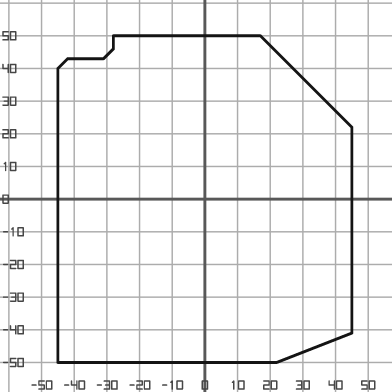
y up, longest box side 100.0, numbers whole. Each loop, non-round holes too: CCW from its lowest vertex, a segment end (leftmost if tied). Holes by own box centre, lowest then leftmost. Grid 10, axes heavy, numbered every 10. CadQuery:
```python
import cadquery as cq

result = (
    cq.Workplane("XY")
    .moveTo(-45.0, -50.0)
    .lineTo(22.0, -50.0)
    .lineTo(45.0, -41.0)
    .lineTo(45.0, 22.0)
    .lineTo(17.0, 50.0)
    .lineTo(-28.0, 50.0)
    .lineTo(-28.0, 46.0)
    .lineTo(-31.0, 43.0)
    .lineTo(-42.0, 43.0)
    .lineTo(-45.0, 40.0)
    .close()
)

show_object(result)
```